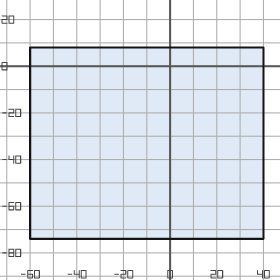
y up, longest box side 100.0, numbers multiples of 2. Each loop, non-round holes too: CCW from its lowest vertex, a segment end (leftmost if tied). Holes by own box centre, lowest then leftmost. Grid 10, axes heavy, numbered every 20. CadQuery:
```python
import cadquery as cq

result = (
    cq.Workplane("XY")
    .moveTo(-60.0, -74.0)
    .lineTo(40.0, -74.0)
    .lineTo(40.0, 8.0)
    .lineTo(-60.0, 8.0)
    .close()
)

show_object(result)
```